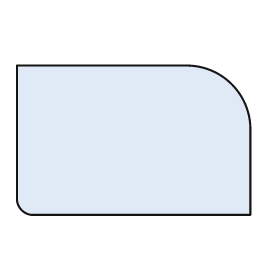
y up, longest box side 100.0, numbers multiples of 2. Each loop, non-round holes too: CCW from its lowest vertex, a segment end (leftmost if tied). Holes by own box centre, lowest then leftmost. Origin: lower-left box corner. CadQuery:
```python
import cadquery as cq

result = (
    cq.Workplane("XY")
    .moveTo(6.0, 0.0)
    .lineTo(100.0, 0.0)
    .lineTo(100.0, 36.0)
    .threePointArc((92.0, 56.0), (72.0, 64.0))
    .lineTo(0.0, 64.0)
    .lineTo(0.0, 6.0)
    .threePointArc((2.0, 2.0), (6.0, 0.0))
    .close()
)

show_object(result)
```